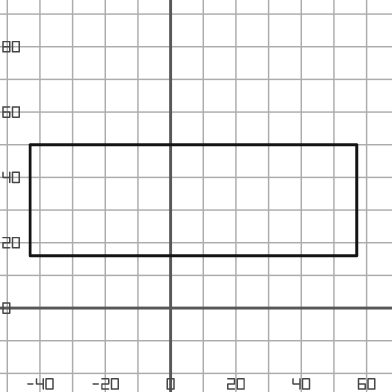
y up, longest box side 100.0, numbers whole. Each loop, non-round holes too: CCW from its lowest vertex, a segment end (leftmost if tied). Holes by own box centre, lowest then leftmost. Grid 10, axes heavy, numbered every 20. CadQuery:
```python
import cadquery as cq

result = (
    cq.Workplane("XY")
    .moveTo(-43.0, 16.0)
    .lineTo(57.0, 16.0)
    .lineTo(57.0, 50.0)
    .lineTo(-43.0, 50.0)
    .close()
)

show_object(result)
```